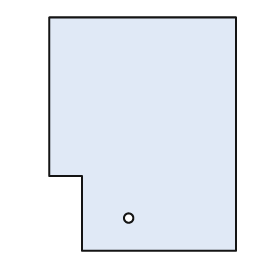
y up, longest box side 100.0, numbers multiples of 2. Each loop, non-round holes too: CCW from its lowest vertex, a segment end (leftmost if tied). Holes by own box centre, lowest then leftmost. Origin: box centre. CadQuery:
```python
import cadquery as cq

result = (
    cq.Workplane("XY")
    .moveTo(-26.0, -50.0)
    .lineTo(40.0, -50.0)
    .lineTo(40.0, 50.0)
    .lineTo(-40.0, 50.0)
    .lineTo(-40.0, -18.0)
    .lineTo(-26.0, -18.0)
    .close()
    .moveTo(-6.0, -36.0)
    .circle(2.0)
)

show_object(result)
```